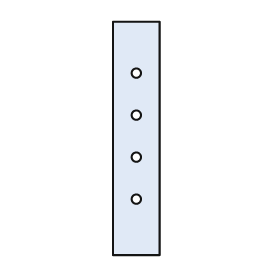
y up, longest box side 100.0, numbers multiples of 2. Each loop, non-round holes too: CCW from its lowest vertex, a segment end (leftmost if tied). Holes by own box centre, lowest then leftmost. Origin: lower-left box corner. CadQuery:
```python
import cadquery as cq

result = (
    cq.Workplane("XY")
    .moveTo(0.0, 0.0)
    .lineTo(20.0, 0.0)
    .lineTo(20.0, 100.0)
    .lineTo(0.0, 100.0)
    .close()
    .moveTo(10.0, 24.0)
    .circle(2.0)
    .moveTo(10.0, 42.0)
    .circle(2.0)
    .moveTo(10.0, 60.0)
    .circle(2.0)
    .moveTo(10.0, 78.0)
    .circle(2.0)
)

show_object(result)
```